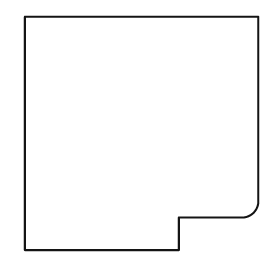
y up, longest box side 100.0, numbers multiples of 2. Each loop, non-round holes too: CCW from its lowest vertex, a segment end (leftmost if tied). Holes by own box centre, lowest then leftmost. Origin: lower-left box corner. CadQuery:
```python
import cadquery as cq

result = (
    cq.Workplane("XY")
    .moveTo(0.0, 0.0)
    .lineTo(66.0, 0.0)
    .lineTo(66.0, 14.0)
    .lineTo(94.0, 14.0)
    .threePointArc((98.0, 16.0), (100.0, 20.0))
    .lineTo(100.0, 100.0)
    .lineTo(0.0, 100.0)
    .close()
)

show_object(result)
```